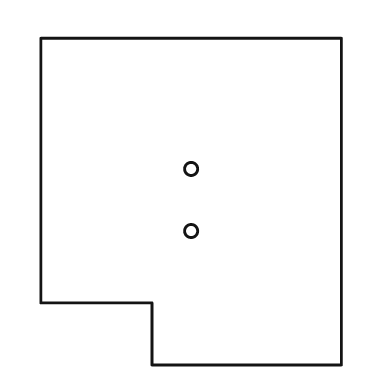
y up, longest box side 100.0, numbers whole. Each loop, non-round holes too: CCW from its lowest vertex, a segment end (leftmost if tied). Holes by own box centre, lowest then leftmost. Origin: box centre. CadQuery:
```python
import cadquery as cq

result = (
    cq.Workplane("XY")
    .moveTo(-12.0, -50.0)
    .lineTo(46.0, -50.0)
    .lineTo(46.0, 50.0)
    .lineTo(-46.0, 50.0)
    .lineTo(-46.0, -31.0)
    .lineTo(-12.0, -31.0)
    .close()
    .moveTo(0.0, -9.0)
    .circle(2.0)
    .moveTo(0.0, 10.0)
    .circle(2.0)
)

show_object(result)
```